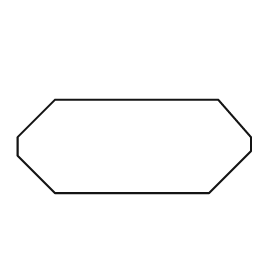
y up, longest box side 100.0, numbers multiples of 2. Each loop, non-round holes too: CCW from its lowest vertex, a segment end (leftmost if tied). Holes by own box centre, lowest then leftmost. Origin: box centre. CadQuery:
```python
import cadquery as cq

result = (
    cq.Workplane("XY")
    .moveTo(-34.0, -20.0)
    .lineTo(32.0, -20.0)
    .lineTo(50.0, -2.0)
    .lineTo(50.0, 4.0)
    .lineTo(36.0, 20.0)
    .lineTo(-34.0, 20.0)
    .lineTo(-50.0, 4.0)
    .lineTo(-50.0, -4.0)
    .close()
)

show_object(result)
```